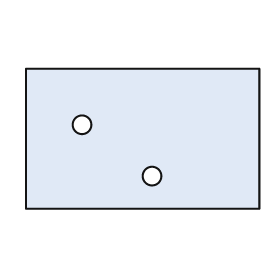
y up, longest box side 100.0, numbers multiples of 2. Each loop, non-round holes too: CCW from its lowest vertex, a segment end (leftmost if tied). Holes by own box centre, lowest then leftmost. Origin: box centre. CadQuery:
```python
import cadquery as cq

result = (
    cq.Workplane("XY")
    .moveTo(-50.0, -30.0)
    .lineTo(50.0, -30.0)
    .lineTo(50.0, 30.0)
    .lineTo(-50.0, 30.0)
    .close()
    .moveTo(4.0, -16.0)
    .circle(4.0)
    .moveTo(-26.0, 6.0)
    .circle(4.0)
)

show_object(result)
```